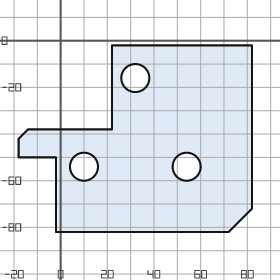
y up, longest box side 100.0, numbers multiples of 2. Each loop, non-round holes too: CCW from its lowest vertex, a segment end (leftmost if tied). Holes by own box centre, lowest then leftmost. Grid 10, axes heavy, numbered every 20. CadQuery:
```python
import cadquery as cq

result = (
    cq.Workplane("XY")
    .moveTo(-2.0, -82.0)
    .lineTo(72.0, -82.0)
    .lineTo(82.0, -72.0)
    .lineTo(82.0, -2.0)
    .lineTo(22.0, -2.0)
    .lineTo(22.0, -38.0)
    .lineTo(-14.0, -38.0)
    .lineTo(-18.0, -42.0)
    .lineTo(-18.0, -50.0)
    .lineTo(-2.0, -50.0)
    .close()
    .moveTo(10.0, -54.0)
    .circle(6.0)
    .moveTo(54.0, -54.0)
    .circle(6.0)
    .moveTo(32.0, -16.0)
    .circle(6.0)
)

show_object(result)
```